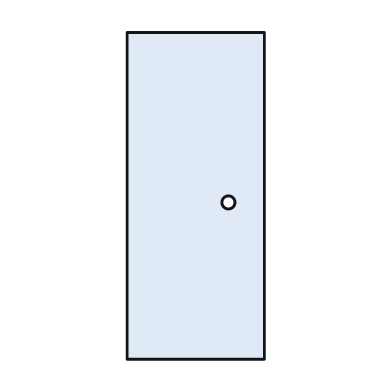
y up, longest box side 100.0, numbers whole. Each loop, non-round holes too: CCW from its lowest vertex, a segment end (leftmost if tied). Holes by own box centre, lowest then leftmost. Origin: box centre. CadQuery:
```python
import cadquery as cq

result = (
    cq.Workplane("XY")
    .moveTo(-21.0, -50.0)
    .lineTo(21.0, -50.0)
    .lineTo(21.0, 50.0)
    .lineTo(-21.0, 50.0)
    .close()
    .moveTo(10.0, -2.0)
    .circle(2.0)
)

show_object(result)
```